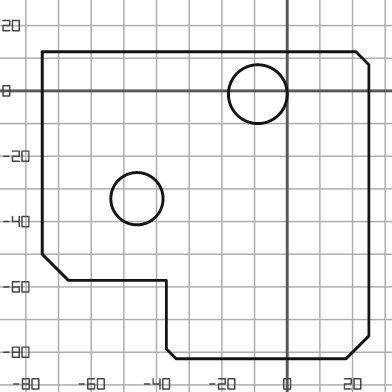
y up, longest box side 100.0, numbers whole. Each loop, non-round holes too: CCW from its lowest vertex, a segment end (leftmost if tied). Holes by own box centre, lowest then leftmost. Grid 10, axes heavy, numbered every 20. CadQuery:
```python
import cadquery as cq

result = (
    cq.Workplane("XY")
    .moveTo(-34.0, -82.0)
    .lineTo(18.0, -82.0)
    .lineTo(25.0, -75.0)
    .lineTo(25.0, 8.0)
    .lineTo(21.0, 12.0)
    .lineTo(-75.0, 12.0)
    .lineTo(-75.0, -50.0)
    .lineTo(-67.0, -58.0)
    .lineTo(-37.0, -58.0)
    .lineTo(-37.0, -79.0)
    .close()
    .moveTo(-46.0, -33.0)
    .circle(8.0)
    .moveTo(-9.0, -1.0)
    .circle(9.0)
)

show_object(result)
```